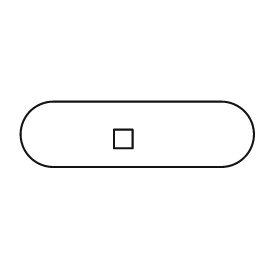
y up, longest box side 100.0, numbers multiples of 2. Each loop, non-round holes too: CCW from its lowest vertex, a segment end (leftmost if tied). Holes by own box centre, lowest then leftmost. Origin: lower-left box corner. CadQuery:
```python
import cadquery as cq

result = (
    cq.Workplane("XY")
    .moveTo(14.0, 0.0)
    .lineTo(86.0, 0.0)
    .threePointArc((100.0, 14.0), (86.0, 28.0))
    .lineTo(14.0, 28.0)
    .threePointArc((0.0, 14.0), (14.0, 0.0))
    .close()
    .moveTo(40.0, 8.0)
    .lineTo(48.0, 8.0)
    .lineTo(48.0, 16.0)
    .lineTo(40.0, 16.0)
    .close()
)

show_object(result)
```